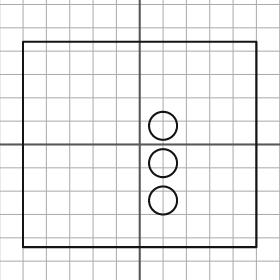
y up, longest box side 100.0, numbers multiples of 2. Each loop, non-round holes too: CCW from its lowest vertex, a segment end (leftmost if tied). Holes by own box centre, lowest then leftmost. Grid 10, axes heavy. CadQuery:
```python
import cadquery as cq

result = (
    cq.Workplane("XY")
    .moveTo(-50.0, -44.0)
    .lineTo(50.0, -44.0)
    .lineTo(50.0, 44.0)
    .lineTo(-50.0, 44.0)
    .close()
    .moveTo(10.0, -24.0)
    .circle(6.0)
    .moveTo(10.0, -8.0)
    .circle(6.0)
    .moveTo(10.0, 8.0)
    .circle(6.0)
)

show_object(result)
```